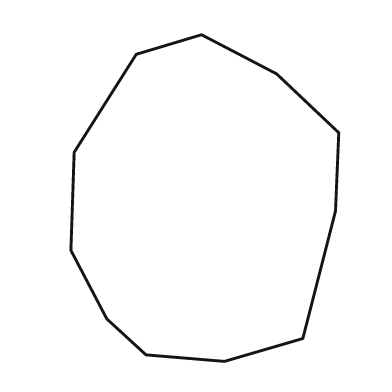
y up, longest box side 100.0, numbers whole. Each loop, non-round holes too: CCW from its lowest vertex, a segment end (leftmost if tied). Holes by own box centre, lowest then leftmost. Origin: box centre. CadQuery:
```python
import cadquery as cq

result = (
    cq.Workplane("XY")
    .moveTo(6.0, -50.0)
    .lineTo(30.0, -43.0)
    .lineTo(40.0, -4.0)
    .lineTo(41.0, 20.0)
    .lineTo(22.0, 38.0)
    .lineTo(-1.0, 50.0)
    .lineTo(-21.0, 44.0)
    .lineTo(-40.0, 14.0)
    .lineTo(-41.0, -16.0)
    .lineTo(-30.0, -37.0)
    .lineTo(-18.0, -48.0)
    .close()
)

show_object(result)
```